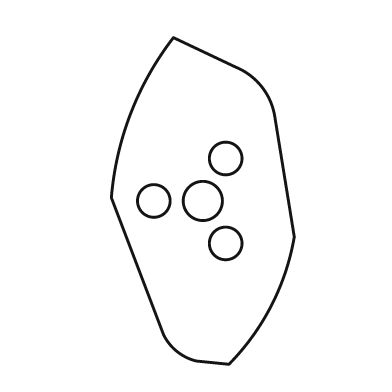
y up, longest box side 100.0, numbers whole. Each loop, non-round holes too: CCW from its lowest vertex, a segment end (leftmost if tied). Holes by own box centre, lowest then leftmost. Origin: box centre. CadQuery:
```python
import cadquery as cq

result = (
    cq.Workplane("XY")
    .moveTo(8.0, -50.0)
    .threePointArc((21.0, -32.0), (28.0, -11.0))
    .lineTo(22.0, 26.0)
    .threePointArc((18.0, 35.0), (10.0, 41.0))
    .lineTo(-9.0, 50.0)
    .threePointArc((-22.0, 27.0), (-28.0, 1.0))
    .lineTo(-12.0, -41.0)
    .threePointArc((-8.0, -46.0), (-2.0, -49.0))
    .close()
    .moveTo(7.0, -13.0)
    .circle(5.0)
    .moveTo(-15.0, 0.0)
    .circle(5.0)
    .moveTo(0.0, 0.0)
    .circle(6.0)
    .moveTo(7.0, 13.0)
    .circle(5.0)
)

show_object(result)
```